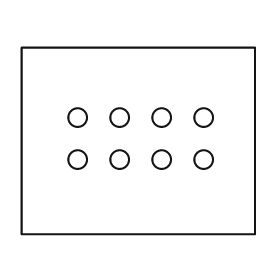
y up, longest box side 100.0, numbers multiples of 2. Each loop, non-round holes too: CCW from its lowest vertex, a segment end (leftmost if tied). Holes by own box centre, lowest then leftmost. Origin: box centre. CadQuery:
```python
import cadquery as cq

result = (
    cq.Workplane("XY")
    .moveTo(-50.0, -40.0)
    .lineTo(50.0, -40.0)
    .lineTo(50.0, 40.0)
    .lineTo(-50.0, 40.0)
    .close()
    .moveTo(-26.0, -8.0)
    .circle(4.0)
    .moveTo(-8.0, -8.0)
    .circle(4.0)
    .moveTo(10.0, -8.0)
    .circle(4.0)
    .moveTo(28.0, -8.0)
    .circle(4.0)
    .moveTo(-26.0, 10.0)
    .circle(4.0)
    .moveTo(-8.0, 10.0)
    .circle(4.0)
    .moveTo(10.0, 10.0)
    .circle(4.0)
    .moveTo(28.0, 10.0)
    .circle(4.0)
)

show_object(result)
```